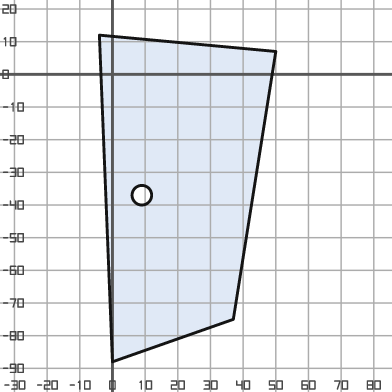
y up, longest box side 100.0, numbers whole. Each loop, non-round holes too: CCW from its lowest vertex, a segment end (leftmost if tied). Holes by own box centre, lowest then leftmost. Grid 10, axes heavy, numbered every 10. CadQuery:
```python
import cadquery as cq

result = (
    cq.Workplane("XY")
    .moveTo(0.0, -88.0)
    .lineTo(37.0, -75.0)
    .lineTo(50.0, 7.0)
    .lineTo(-4.0, 12.0)
    .close()
    .moveTo(9.0, -37.0)
    .circle(3.0)
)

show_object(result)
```